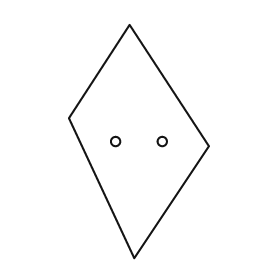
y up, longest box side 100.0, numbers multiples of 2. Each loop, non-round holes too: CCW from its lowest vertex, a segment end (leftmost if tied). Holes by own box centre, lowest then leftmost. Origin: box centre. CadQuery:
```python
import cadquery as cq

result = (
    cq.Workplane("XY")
    .moveTo(-2.0, -50.0)
    .lineTo(30.0, -2.0)
    .lineTo(-4.0, 50.0)
    .lineTo(-30.0, 10.0)
    .close()
    .moveTo(-10.0, 0.0)
    .circle(2.0)
    .moveTo(10.0, 0.0)
    .circle(2.0)
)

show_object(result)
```